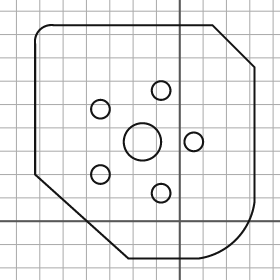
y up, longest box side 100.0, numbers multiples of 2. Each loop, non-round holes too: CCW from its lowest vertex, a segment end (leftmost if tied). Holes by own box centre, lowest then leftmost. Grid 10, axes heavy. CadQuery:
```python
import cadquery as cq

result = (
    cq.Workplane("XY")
    .moveTo(-22.0, -16.0)
    .lineTo(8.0, -16.0)
    .threePointArc((24.0, -8.0), (32.0, 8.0))
    .lineTo(32.0, 66.0)
    .lineTo(14.0, 84.0)
    .lineTo(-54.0, 84.0)
    .threePointArc((-60.0, 82.0), (-62.0, 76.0))
    .lineTo(-62.0, 20.0)
    .close()
    .moveTo(-8.0, 12.0)
    .circle(4.0)
    .moveTo(-34.0, 20.0)
    .circle(4.0)
    .moveTo(-16.0, 34.0)
    .circle(8.0)
    .moveTo(6.0, 34.0)
    .circle(4.0)
    .moveTo(-34.0, 48.0)
    .circle(4.0)
    .moveTo(-8.0, 56.0)
    .circle(4.0)
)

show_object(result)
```